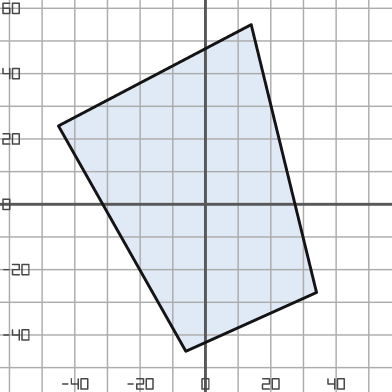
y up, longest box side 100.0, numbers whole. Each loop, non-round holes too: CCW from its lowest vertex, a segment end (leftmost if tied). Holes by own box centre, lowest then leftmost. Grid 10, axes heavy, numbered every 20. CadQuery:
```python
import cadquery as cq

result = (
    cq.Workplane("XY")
    .moveTo(-6.0, -45.0)
    .lineTo(34.0, -27.0)
    .lineTo(14.0, 55.0)
    .lineTo(-45.0, 24.0)
    .close()
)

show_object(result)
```